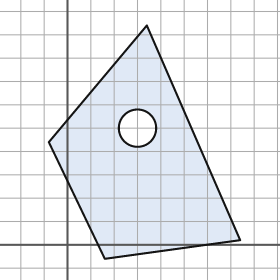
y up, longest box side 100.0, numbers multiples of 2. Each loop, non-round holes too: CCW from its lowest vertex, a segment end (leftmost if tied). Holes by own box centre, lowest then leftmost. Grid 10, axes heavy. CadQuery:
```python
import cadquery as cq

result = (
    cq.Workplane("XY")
    .moveTo(16.0, -6.0)
    .lineTo(74.0, 2.0)
    .lineTo(34.0, 94.0)
    .lineTo(-8.0, 44.0)
    .close()
    .moveTo(30.0, 50.0)
    .circle(8.0)
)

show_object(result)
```